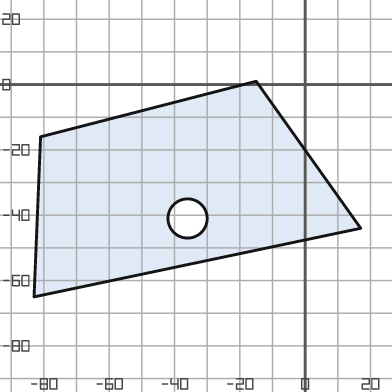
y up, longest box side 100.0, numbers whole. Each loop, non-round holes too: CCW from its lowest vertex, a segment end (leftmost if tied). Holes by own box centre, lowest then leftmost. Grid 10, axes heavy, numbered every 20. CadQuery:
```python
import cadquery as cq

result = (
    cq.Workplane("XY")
    .moveTo(-83.0, -65.0)
    .lineTo(17.0, -44.0)
    .lineTo(-15.0, 1.0)
    .lineTo(-81.0, -16.0)
    .close()
    .moveTo(-36.0, -41.0)
    .circle(6.0)
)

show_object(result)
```